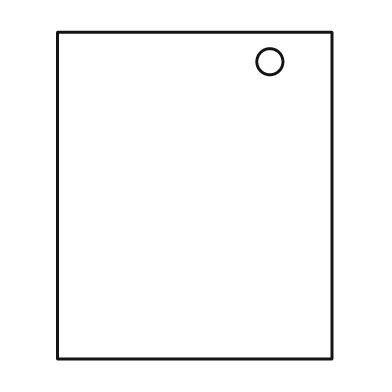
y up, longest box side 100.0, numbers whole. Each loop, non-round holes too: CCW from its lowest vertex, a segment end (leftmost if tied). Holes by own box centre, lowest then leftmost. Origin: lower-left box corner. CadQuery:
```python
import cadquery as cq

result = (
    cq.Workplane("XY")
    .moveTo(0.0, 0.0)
    .lineTo(84.0, 0.0)
    .lineTo(84.0, 100.0)
    .lineTo(0.0, 100.0)
    .close()
    .moveTo(65.0, 91.0)
    .circle(4.0)
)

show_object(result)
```